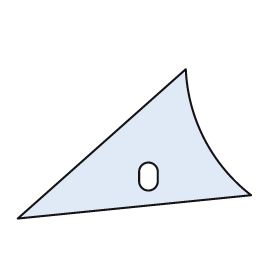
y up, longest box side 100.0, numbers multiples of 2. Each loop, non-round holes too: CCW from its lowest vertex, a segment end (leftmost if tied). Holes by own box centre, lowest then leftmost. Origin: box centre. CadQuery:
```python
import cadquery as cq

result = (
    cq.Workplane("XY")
    .moveTo(-50.0, -32.0)
    .lineTo(50.0, -22.0)
    .threePointArc((30.0, 2.0), (22.0, 32.0))
    .close()
    .moveTo(2.0, -16.0)
    .threePointArc((6.0, -20.0), (10.0, -16.0))
    .lineTo(10.0, -12.0)
    .threePointArc((6.0, -8.0), (2.0, -12.0))
    .close()
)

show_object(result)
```